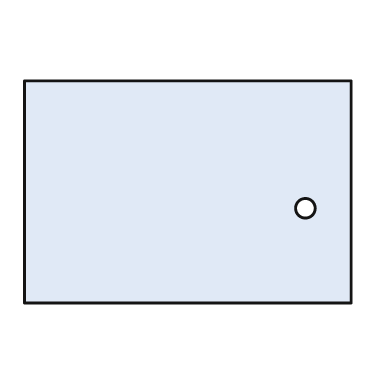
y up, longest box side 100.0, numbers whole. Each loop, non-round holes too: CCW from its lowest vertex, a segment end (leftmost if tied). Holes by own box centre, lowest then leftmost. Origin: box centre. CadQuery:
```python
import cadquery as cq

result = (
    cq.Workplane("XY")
    .moveTo(-50.0, -34.0)
    .lineTo(50.0, -34.0)
    .lineTo(50.0, 34.0)
    .lineTo(-50.0, 34.0)
    .close()
    .moveTo(36.0, -5.0)
    .circle(3.0)
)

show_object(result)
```